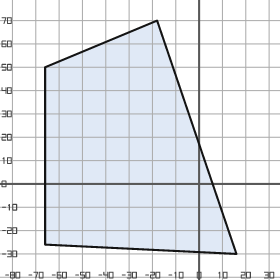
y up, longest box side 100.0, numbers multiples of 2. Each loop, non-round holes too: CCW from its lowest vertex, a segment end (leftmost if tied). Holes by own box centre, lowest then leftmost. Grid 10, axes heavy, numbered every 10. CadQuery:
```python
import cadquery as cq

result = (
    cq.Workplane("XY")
    .moveTo(16.0, -30.0)
    .lineTo(-18.0, 70.0)
    .lineTo(-66.0, 50.0)
    .lineTo(-66.0, -26.0)
    .close()
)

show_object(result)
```